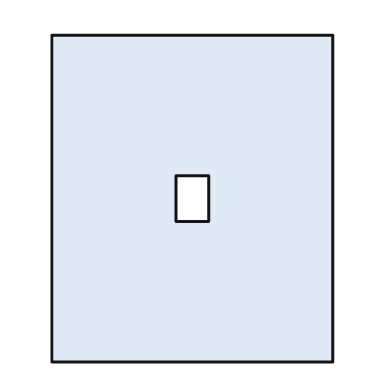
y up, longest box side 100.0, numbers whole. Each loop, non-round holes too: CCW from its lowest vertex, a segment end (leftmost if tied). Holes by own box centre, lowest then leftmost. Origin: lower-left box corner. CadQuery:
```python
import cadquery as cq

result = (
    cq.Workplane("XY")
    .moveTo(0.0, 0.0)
    .lineTo(86.0, 0.0)
    .lineTo(86.0, 100.0)
    .lineTo(0.0, 100.0)
    .close()
    .moveTo(38.0, 43.0)
    .lineTo(48.0, 43.0)
    .lineTo(48.0, 57.0)
    .lineTo(38.0, 57.0)
    .close()
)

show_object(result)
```